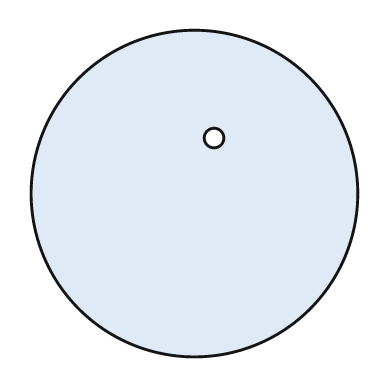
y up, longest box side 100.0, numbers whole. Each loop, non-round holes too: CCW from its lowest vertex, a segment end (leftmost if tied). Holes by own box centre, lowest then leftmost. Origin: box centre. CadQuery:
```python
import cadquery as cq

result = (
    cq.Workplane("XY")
    .moveTo(0.0, 0.0)
    .circle(50.0)
    .moveTo(6.0, 17.0)
    .circle(3.0)
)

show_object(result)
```